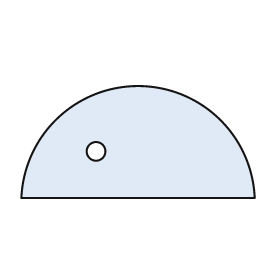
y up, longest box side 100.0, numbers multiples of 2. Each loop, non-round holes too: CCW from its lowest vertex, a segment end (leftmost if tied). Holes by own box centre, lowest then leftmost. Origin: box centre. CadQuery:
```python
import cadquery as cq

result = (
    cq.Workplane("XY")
    .moveTo(-50.0, -24.0)
    .lineTo(50.0, -24.0)
    .threePointArc((0.0, 24.0), (-50.0, -24.0))
    .close()
    .moveTo(-18.0, -4.0)
    .circle(4.0)
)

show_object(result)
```